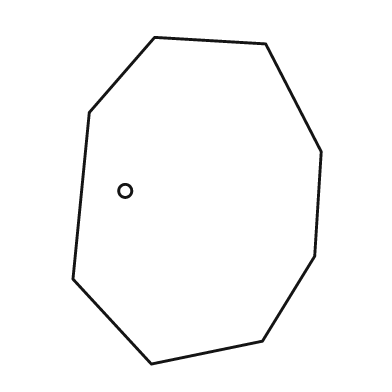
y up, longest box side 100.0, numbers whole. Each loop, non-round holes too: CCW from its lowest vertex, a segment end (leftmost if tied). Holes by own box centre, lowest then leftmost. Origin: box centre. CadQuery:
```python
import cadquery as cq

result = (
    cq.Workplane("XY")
    .moveTo(-14.0, -50.0)
    .lineTo(20.0, -43.0)
    .lineTo(36.0, -17.0)
    .lineTo(38.0, 15.0)
    .lineTo(21.0, 48.0)
    .lineTo(-13.0, 50.0)
    .lineTo(-33.0, 27.0)
    .lineTo(-38.0, -24.0)
    .close()
    .moveTo(-22.0, 3.0)
    .circle(2.0)
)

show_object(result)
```